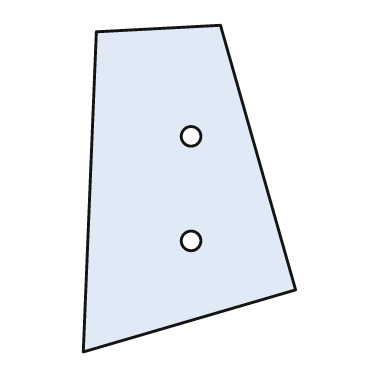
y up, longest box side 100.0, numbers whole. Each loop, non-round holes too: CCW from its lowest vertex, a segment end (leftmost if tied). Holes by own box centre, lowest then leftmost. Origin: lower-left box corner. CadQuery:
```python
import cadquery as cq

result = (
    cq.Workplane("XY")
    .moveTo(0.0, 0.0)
    .lineTo(65.0, 19.0)
    .lineTo(42.0, 100.0)
    .lineTo(4.0, 98.0)
    .close()
    .moveTo(33.0, 34.0)
    .circle(3.0)
    .moveTo(33.0, 66.0)
    .circle(3.0)
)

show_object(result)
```